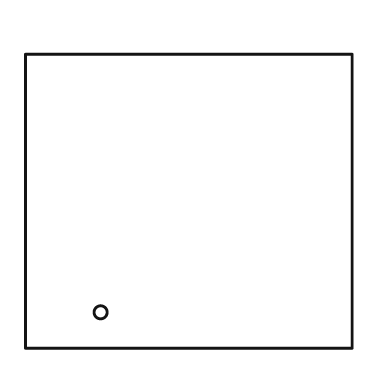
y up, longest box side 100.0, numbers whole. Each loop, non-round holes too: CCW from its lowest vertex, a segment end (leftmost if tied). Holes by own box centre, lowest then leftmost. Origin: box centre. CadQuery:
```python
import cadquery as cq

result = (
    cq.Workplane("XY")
    .moveTo(-50.0, -45.0)
    .lineTo(50.0, -45.0)
    .lineTo(50.0, 45.0)
    .lineTo(-50.0, 45.0)
    .close()
    .moveTo(-27.0, -34.0)
    .circle(2.0)
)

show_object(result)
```